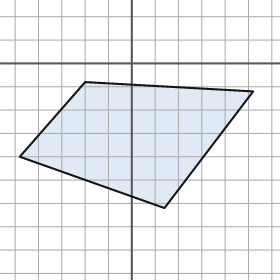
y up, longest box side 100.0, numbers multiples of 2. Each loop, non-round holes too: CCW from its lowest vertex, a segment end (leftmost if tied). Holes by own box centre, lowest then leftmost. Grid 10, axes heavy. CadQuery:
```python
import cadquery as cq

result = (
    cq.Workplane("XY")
    .moveTo(14.0, -62.0)
    .lineTo(52.0, -12.0)
    .lineTo(-20.0, -8.0)
    .lineTo(-48.0, -40.0)
    .close()
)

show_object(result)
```